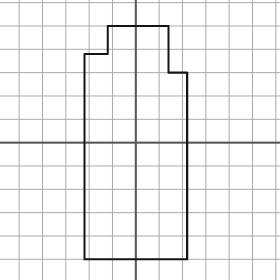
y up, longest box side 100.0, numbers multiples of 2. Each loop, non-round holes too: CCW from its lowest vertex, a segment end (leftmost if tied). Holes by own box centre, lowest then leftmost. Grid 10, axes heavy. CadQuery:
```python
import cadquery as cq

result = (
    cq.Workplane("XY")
    .moveTo(-22.0, -50.0)
    .lineTo(22.0, -50.0)
    .lineTo(22.0, 30.0)
    .lineTo(14.0, 30.0)
    .lineTo(14.0, 50.0)
    .lineTo(-12.0, 50.0)
    .lineTo(-12.0, 38.0)
    .lineTo(-22.0, 38.0)
    .close()
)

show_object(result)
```